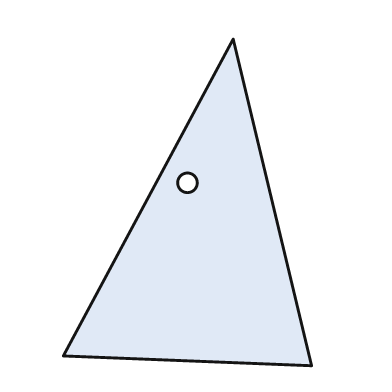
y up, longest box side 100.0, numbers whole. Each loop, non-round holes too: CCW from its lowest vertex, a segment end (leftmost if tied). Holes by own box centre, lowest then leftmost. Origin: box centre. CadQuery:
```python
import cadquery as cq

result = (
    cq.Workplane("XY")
    .moveTo(38.0, -50.0)
    .lineTo(14.0, 50.0)
    .lineTo(-38.0, -47.0)
    .close()
    .moveTo(0.0, 6.0)
    .circle(3.0)
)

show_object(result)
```